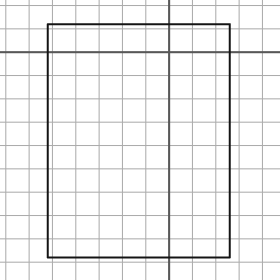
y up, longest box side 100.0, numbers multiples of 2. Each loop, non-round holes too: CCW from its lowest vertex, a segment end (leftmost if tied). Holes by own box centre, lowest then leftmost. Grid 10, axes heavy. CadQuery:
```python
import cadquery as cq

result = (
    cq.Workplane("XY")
    .moveTo(-52.0, -88.0)
    .lineTo(26.0, -88.0)
    .lineTo(26.0, 12.0)
    .lineTo(-52.0, 12.0)
    .close()
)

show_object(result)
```